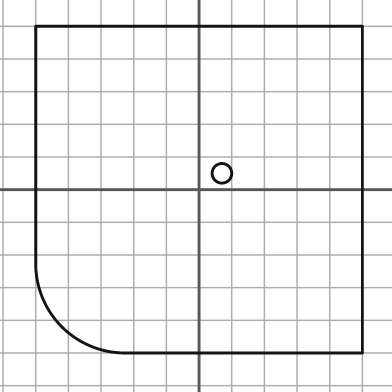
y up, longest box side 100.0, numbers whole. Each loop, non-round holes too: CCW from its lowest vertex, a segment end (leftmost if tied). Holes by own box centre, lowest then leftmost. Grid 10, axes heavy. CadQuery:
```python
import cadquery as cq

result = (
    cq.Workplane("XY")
    .moveTo(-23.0, -50.0)
    .lineTo(50.0, -50.0)
    .lineTo(50.0, 50.0)
    .lineTo(-50.0, 50.0)
    .lineTo(-50.0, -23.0)
    .threePointArc((-42.0, -42.0), (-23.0, -50.0))
    .close()
    .moveTo(7.0, 5.0)
    .circle(3.0)
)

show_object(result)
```